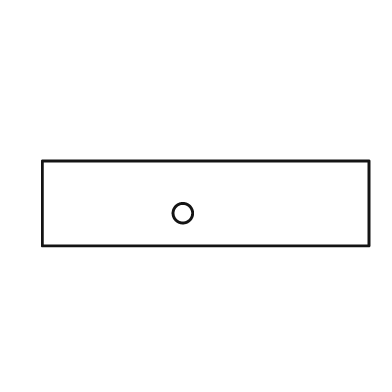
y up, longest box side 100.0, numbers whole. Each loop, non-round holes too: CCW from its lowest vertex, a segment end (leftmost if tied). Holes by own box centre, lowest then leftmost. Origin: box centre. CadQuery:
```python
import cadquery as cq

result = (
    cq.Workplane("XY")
    .moveTo(-50.0, -13.0)
    .lineTo(50.0, -13.0)
    .lineTo(50.0, 13.0)
    .lineTo(-50.0, 13.0)
    .close()
    .moveTo(-7.0, -3.0)
    .circle(3.0)
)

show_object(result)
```